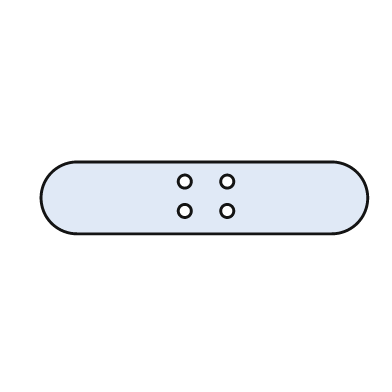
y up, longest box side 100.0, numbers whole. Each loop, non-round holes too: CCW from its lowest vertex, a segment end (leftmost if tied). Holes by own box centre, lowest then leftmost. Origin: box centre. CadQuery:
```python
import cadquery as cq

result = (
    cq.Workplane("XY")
    .moveTo(-39.0, -11.0)
    .lineTo(39.0, -11.0)
    .threePointArc((50.0, 0.0), (39.0, 11.0))
    .lineTo(-39.0, 11.0)
    .threePointArc((-50.0, 0.0), (-39.0, -11.0))
    .close()
    .moveTo(-6.0, -4.0)
    .circle(2.0)
    .moveTo(7.0, -4.0)
    .circle(2.0)
    .moveTo(-6.0, 5.0)
    .circle(2.0)
    .moveTo(7.0, 5.0)
    .circle(2.0)
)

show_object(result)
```